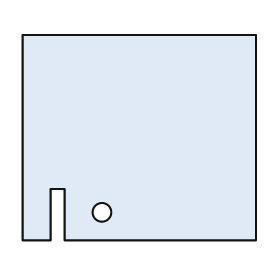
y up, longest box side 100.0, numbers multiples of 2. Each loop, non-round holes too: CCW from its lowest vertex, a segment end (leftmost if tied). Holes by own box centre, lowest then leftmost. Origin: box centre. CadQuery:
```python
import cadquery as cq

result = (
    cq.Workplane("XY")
    .moveTo(-50.0, -44.0)
    .lineTo(-38.0, -44.0)
    .lineTo(-38.0, -22.0)
    .lineTo(-32.0, -22.0)
    .lineTo(-32.0, -44.0)
    .lineTo(50.0, -44.0)
    .lineTo(50.0, 44.0)
    .lineTo(-50.0, 44.0)
    .close()
    .moveTo(-16.0, -32.0)
    .circle(4.0)
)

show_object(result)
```